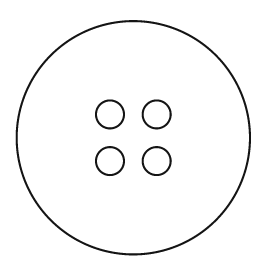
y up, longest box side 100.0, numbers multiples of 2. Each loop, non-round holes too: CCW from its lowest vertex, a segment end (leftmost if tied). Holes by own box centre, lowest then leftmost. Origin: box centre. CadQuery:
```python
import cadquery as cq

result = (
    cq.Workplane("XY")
    .moveTo(0.0, 0.0)
    .circle(50.0)
    .moveTo(-10.0, -10.0)
    .circle(6.0)
    .moveTo(10.0, -10.0)
    .circle(6.0)
    .moveTo(-10.0, 10.0)
    .circle(6.0)
    .moveTo(10.0, 10.0)
    .circle(6.0)
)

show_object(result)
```